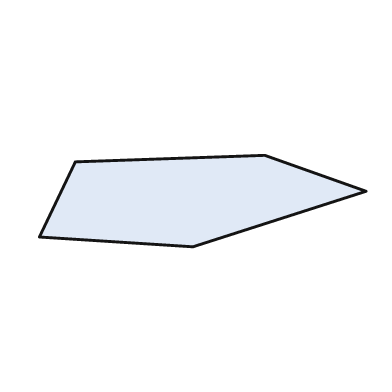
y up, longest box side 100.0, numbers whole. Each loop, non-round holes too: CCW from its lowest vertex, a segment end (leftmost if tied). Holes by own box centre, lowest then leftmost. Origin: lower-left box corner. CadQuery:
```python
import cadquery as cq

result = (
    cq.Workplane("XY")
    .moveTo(47.0, 0.0)
    .lineTo(100.0, 17.0)
    .lineTo(69.0, 28.0)
    .lineTo(11.0, 26.0)
    .lineTo(0.0, 3.0)
    .close()
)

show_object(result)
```